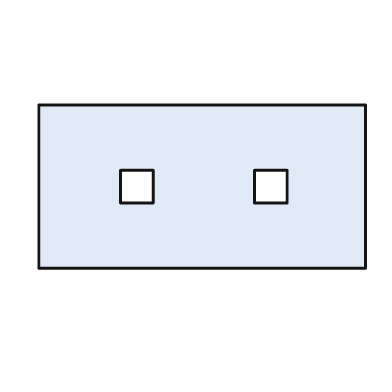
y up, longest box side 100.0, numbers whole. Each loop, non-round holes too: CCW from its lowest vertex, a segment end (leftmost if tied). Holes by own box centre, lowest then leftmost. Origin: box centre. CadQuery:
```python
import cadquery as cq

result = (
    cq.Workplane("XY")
    .moveTo(-50.0, -25.0)
    .lineTo(50.0, -25.0)
    .lineTo(50.0, 25.0)
    .lineTo(-50.0, 25.0)
    .close()
    .moveTo(-25.0, -5.0)
    .lineTo(-15.0, -5.0)
    .lineTo(-15.0, 5.0)
    .lineTo(-25.0, 5.0)
    .close()
    .moveTo(16.0, -5.0)
    .lineTo(26.0, -5.0)
    .lineTo(26.0, 5.0)
    .lineTo(16.0, 5.0)
    .close()
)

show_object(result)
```